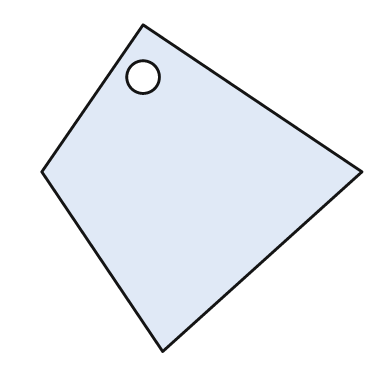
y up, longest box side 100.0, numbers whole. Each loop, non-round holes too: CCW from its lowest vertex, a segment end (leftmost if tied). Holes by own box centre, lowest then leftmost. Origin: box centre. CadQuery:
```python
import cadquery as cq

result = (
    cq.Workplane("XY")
    .moveTo(-12.0, -50.0)
    .lineTo(49.0, 5.0)
    .lineTo(-18.0, 50.0)
    .lineTo(-49.0, 5.0)
    .close()
    .moveTo(-18.0, 34.0)
    .circle(5.0)
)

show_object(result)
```